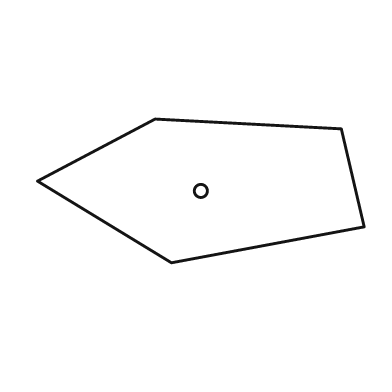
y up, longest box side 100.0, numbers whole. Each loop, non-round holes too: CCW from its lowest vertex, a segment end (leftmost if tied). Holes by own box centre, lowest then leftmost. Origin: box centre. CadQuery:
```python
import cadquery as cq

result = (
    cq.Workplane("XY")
    .moveTo(-9.0, -22.0)
    .lineTo(50.0, -11.0)
    .lineTo(43.0, 19.0)
    .lineTo(-14.0, 22.0)
    .lineTo(-50.0, 3.0)
    .close()
    .moveTo(0.0, 0.0)
    .circle(2.0)
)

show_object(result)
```